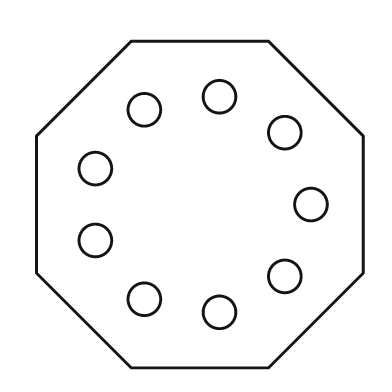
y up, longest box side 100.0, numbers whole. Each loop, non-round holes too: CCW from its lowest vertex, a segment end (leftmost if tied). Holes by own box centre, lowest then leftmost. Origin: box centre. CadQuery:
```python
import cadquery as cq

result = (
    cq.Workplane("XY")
    .moveTo(-21.0, -50.0)
    .lineTo(21.0, -50.0)
    .lineTo(50.0, -21.0)
    .lineTo(50.0, 21.0)
    .lineTo(21.0, 50.0)
    .lineTo(-21.0, 50.0)
    .lineTo(-50.0, 21.0)
    .lineTo(-50.0, -21.0)
    .close()
    .moveTo(6.0, -33.0)
    .circle(5.0)
    .moveTo(-17.0, -29.0)
    .circle(5.0)
    .moveTo(26.0, -22.0)
    .circle(5.0)
    .moveTo(-32.0, -11.0)
    .circle(5.0)
    .moveTo(34.0, 0.0)
    .circle(5.0)
    .moveTo(-32.0, 11.0)
    .circle(5.0)
    .moveTo(26.0, 22.0)
    .circle(5.0)
    .moveTo(-17.0, 29.0)
    .circle(5.0)
    .moveTo(6.0, 33.0)
    .circle(5.0)
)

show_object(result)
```